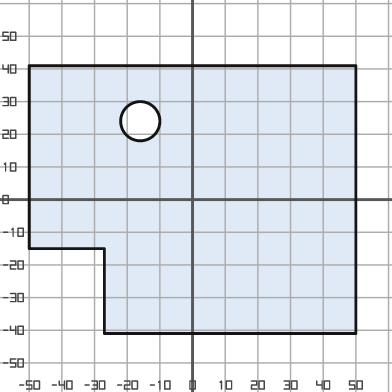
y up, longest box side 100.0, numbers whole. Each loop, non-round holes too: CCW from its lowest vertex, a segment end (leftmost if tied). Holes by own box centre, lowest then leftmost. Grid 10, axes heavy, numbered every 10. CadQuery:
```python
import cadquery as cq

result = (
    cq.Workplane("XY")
    .moveTo(-27.0, -41.0)
    .lineTo(50.0, -41.0)
    .lineTo(50.0, 41.0)
    .lineTo(-50.0, 41.0)
    .lineTo(-50.0, -15.0)
    .lineTo(-27.0, -15.0)
    .close()
    .moveTo(-16.0, 24.0)
    .circle(6.0)
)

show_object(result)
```